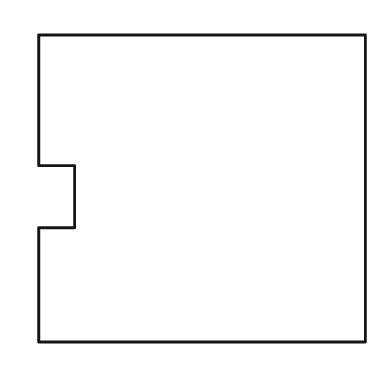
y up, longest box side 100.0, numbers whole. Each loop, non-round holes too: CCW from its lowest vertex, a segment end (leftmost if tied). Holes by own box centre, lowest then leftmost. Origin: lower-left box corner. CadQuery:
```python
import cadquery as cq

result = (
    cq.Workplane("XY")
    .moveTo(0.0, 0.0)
    .lineTo(100.0, 0.0)
    .lineTo(100.0, 94.0)
    .lineTo(0.0, 94.0)
    .lineTo(0.0, 54.0)
    .lineTo(11.0, 54.0)
    .lineTo(11.0, 35.0)
    .lineTo(0.0, 35.0)
    .close()
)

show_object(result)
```